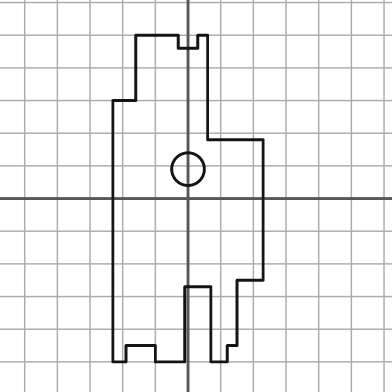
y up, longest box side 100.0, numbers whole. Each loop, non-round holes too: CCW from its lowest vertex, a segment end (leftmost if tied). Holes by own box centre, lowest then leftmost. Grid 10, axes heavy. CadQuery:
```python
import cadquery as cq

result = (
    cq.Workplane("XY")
    .moveTo(-23.0, -50.0)
    .lineTo(-19.0, -50.0)
    .lineTo(-19.0, -45.0)
    .lineTo(-10.0, -45.0)
    .lineTo(-10.0, -50.0)
    .lineTo(-1.0, -50.0)
    .lineTo(-1.0, -27.0)
    .lineTo(7.0, -27.0)
    .lineTo(7.0, -50.0)
    .lineTo(12.0, -50.0)
    .lineTo(12.0, -45.0)
    .lineTo(15.0, -45.0)
    .lineTo(15.0, -25.0)
    .lineTo(23.0, -25.0)
    .lineTo(23.0, 18.0)
    .lineTo(6.0, 18.0)
    .lineTo(6.0, 50.0)
    .lineTo(3.0, 50.0)
    .lineTo(3.0, 46.0)
    .lineTo(-3.0, 46.0)
    .lineTo(-3.0, 50.0)
    .lineTo(-16.0, 50.0)
    .lineTo(-16.0, 30.0)
    .lineTo(-23.0, 30.0)
    .close()
    .moveTo(0.0, 9.0)
    .circle(5.0)
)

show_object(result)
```